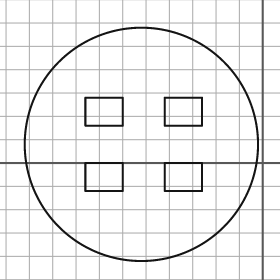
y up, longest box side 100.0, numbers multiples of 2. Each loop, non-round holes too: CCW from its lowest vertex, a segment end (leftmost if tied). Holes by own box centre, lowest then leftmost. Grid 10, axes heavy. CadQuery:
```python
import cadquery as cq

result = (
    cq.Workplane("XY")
    .moveTo(-52.0, 8.0)
    .circle(50.0)
    .moveTo(-76.0, -12.0)
    .lineTo(-60.0, -12.0)
    .lineTo(-60.0, 0.0)
    .lineTo(-76.0, 0.0)
    .close()
    .moveTo(-42.0, -12.0)
    .lineTo(-26.0, -12.0)
    .lineTo(-26.0, 0.0)
    .lineTo(-42.0, 0.0)
    .close()
    .moveTo(-76.0, 16.0)
    .lineTo(-60.0, 16.0)
    .lineTo(-60.0, 28.0)
    .lineTo(-76.0, 28.0)
    .close()
    .moveTo(-42.0, 16.0)
    .lineTo(-26.0, 16.0)
    .lineTo(-26.0, 28.0)
    .lineTo(-42.0, 28.0)
    .close()
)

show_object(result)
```